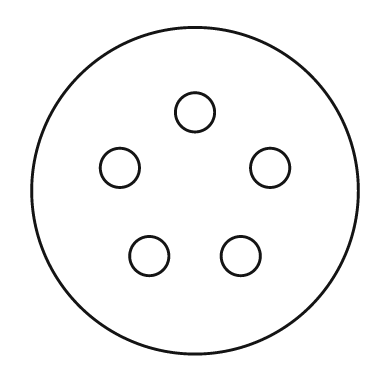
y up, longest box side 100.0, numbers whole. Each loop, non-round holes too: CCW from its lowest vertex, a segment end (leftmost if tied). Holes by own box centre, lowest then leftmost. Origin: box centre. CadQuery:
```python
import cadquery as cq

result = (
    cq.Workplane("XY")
    .moveTo(0.0, 0.0)
    .circle(50.0)
    .moveTo(-14.0, -20.0)
    .circle(6.0)
    .moveTo(14.0, -20.0)
    .circle(6.0)
    .moveTo(-23.0, 7.0)
    .circle(6.0)
    .moveTo(23.0, 7.0)
    .circle(6.0)
    .moveTo(0.0, 24.0)
    .circle(6.0)
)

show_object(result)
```